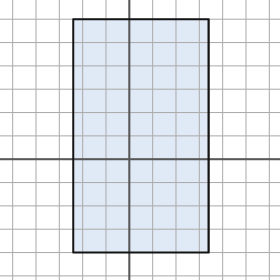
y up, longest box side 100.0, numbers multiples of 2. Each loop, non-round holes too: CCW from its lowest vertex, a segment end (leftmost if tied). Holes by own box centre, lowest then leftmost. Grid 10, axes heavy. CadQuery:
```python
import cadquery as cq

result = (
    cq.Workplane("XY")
    .moveTo(-24.0, -40.0)
    .lineTo(34.0, -40.0)
    .lineTo(34.0, 60.0)
    .lineTo(-24.0, 60.0)
    .close()
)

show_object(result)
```